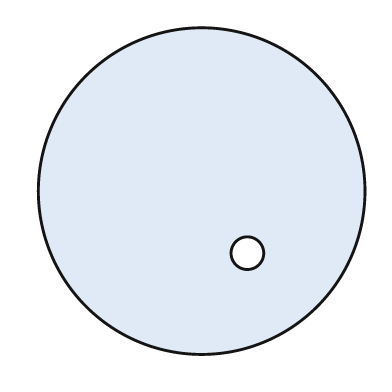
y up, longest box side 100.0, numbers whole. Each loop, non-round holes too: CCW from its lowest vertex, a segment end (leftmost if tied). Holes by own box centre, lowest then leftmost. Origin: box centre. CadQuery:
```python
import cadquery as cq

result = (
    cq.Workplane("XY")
    .moveTo(0.0, 0.0)
    .circle(50.0)
    .moveTo(14.0, -19.0)
    .circle(5.0)
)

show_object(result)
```